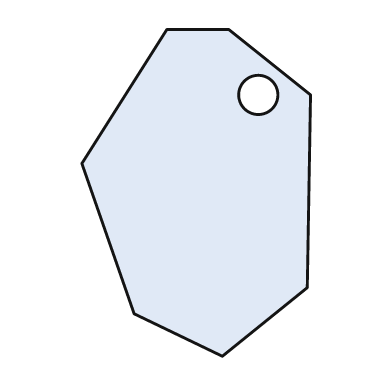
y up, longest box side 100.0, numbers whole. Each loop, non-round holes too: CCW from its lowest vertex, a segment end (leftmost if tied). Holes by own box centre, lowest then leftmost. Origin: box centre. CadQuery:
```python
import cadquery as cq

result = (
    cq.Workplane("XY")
    .moveTo(8.0, -50.0)
    .lineTo(34.0, -29.0)
    .lineTo(35.0, 30.0)
    .lineTo(10.0, 50.0)
    .lineTo(-9.0, 50.0)
    .lineTo(-35.0, 9.0)
    .lineTo(-19.0, -37.0)
    .close()
    .moveTo(19.0, 30.0)
    .circle(6.0)
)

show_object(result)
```